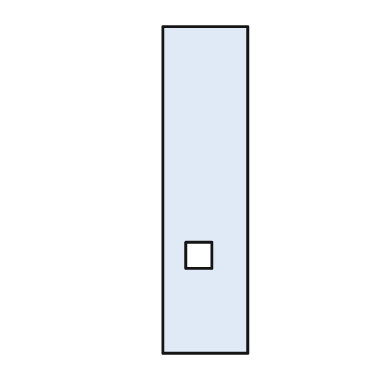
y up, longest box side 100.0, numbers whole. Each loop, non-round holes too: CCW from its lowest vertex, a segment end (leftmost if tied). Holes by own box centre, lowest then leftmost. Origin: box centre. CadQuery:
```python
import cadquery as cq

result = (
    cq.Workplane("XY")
    .moveTo(-13.0, -50.0)
    .lineTo(13.0, -50.0)
    .lineTo(13.0, 50.0)
    .lineTo(-13.0, 50.0)
    .close()
    .moveTo(-6.0, -24.0)
    .lineTo(2.0, -24.0)
    .lineTo(2.0, -16.0)
    .lineTo(-6.0, -16.0)
    .close()
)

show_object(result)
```